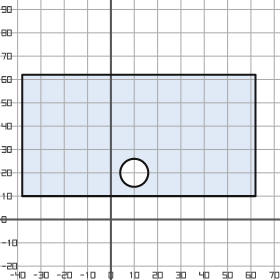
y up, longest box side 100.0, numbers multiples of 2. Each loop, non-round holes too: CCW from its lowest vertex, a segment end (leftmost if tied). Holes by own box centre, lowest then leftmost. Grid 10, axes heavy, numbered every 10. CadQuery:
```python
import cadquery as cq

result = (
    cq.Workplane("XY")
    .moveTo(-38.0, 10.0)
    .lineTo(62.0, 10.0)
    .lineTo(62.0, 62.0)
    .lineTo(-38.0, 62.0)
    .close()
    .moveTo(10.0, 20.0)
    .circle(6.0)
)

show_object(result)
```